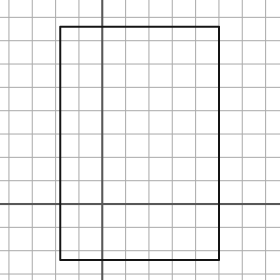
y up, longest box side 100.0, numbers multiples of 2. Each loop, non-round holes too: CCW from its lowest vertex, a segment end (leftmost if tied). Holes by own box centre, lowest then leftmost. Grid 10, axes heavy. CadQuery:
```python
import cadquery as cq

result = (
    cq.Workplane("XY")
    .moveTo(-18.0, -24.0)
    .lineTo(50.0, -24.0)
    .lineTo(50.0, 76.0)
    .lineTo(-18.0, 76.0)
    .close()
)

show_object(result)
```